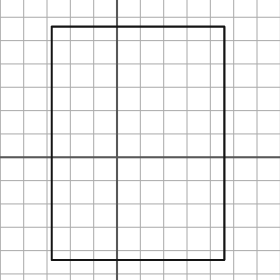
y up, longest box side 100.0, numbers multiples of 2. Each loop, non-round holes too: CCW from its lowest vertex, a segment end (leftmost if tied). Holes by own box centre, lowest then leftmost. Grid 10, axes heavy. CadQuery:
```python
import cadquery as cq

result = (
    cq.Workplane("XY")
    .moveTo(-28.0, -44.0)
    .lineTo(46.0, -44.0)
    .lineTo(46.0, 56.0)
    .lineTo(-28.0, 56.0)
    .close()
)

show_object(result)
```